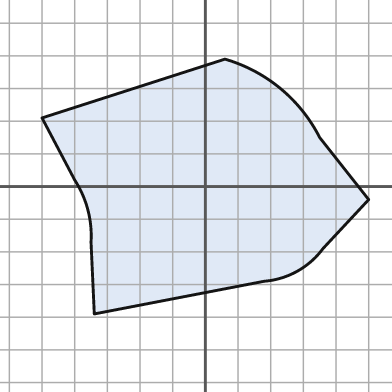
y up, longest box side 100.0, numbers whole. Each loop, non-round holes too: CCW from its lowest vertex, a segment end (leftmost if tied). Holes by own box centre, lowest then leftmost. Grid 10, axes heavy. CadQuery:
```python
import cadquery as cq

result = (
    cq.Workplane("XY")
    .moveTo(-34.0, -39.0)
    .lineTo(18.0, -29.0)
    .threePointArc((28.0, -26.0), (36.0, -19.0))
    .lineTo(50.0, -4.0)
    .lineTo(35.0, 15.0)
    .threePointArc((23.0, 30.0), (6.0, 39.0))
    .lineTo(-50.0, 21.0)
    .lineTo(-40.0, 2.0)
    .threePointArc((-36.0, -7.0), (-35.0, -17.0))
    .close()
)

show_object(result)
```